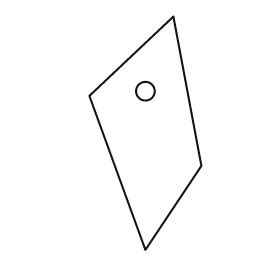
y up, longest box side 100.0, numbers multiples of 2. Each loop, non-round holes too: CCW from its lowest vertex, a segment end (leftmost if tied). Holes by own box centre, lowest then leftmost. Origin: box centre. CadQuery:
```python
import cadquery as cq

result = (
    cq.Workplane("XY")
    .moveTo(0.0, -50.0)
    .lineTo(24.0, -14.0)
    .lineTo(12.0, 50.0)
    .lineTo(-24.0, 16.0)
    .close()
    .moveTo(0.0, 18.0)
    .circle(4.0)
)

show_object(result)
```